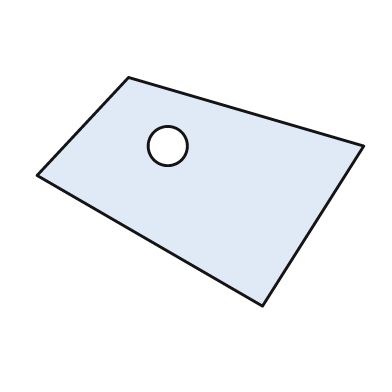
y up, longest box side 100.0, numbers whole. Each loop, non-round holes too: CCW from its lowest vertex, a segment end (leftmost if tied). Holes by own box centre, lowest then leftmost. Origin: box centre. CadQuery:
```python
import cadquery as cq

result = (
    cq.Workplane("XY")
    .moveTo(19.0, -35.0)
    .lineTo(50.0, 14.0)
    .lineTo(-22.0, 35.0)
    .lineTo(-50.0, 5.0)
    .close()
    .moveTo(-10.0, 14.0)
    .circle(6.0)
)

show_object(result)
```